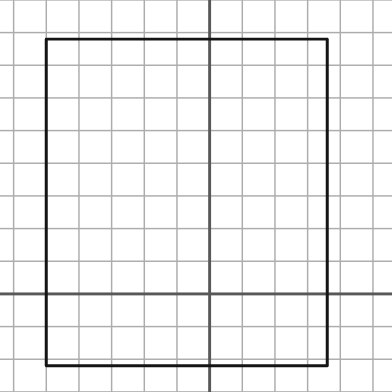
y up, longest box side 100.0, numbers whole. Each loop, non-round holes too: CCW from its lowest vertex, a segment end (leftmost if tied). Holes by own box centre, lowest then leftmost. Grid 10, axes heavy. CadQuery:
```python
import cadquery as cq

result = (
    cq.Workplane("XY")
    .moveTo(-50.0, -22.0)
    .lineTo(36.0, -22.0)
    .lineTo(36.0, 78.0)
    .lineTo(-50.0, 78.0)
    .close()
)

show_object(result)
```